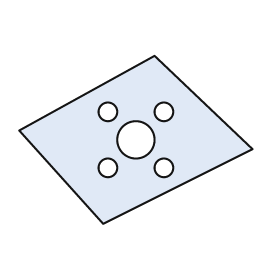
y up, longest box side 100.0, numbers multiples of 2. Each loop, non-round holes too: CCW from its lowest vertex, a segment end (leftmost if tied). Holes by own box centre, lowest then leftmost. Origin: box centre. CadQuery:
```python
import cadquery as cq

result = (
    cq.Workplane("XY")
    .moveTo(-14.0, -36.0)
    .lineTo(50.0, -4.0)
    .lineTo(8.0, 36.0)
    .lineTo(-50.0, 4.0)
    .close()
    .moveTo(-12.0, -12.0)
    .circle(4.0)
    .moveTo(12.0, -12.0)
    .circle(4.0)
    .moveTo(0.0, 0.0)
    .circle(8.0)
    .moveTo(-12.0, 12.0)
    .circle(4.0)
    .moveTo(12.0, 12.0)
    .circle(4.0)
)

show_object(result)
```